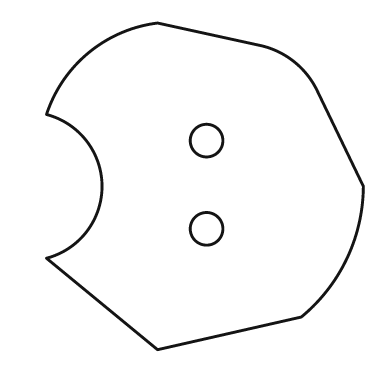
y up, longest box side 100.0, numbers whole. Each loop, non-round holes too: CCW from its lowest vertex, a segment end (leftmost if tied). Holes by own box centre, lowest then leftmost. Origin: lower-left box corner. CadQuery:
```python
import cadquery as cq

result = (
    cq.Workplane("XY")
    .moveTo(34.0, 0.0)
    .lineTo(78.0, 10.0)
    .threePointArc((92.0, 28.0), (97.0, 50.0))
    .lineTo(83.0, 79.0)
    .threePointArc((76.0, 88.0), (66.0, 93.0))
    .lineTo(34.0, 100.0)
    .threePointArc((13.0, 91.0), (0.0, 72.0))
    .threePointArc((17.0, 50.0), (0.0, 28.0))
    .close()
    .moveTo(49.0, 37.0)
    .circle(5.0)
    .moveTo(49.0, 64.0)
    .circle(5.0)
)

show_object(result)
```